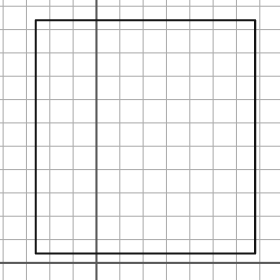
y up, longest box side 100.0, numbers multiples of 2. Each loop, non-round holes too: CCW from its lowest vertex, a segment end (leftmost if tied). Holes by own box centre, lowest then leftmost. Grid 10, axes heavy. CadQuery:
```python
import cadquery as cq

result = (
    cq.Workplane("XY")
    .moveTo(-26.0, 4.0)
    .lineTo(68.0, 4.0)
    .lineTo(68.0, 104.0)
    .lineTo(-26.0, 104.0)
    .close()
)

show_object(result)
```